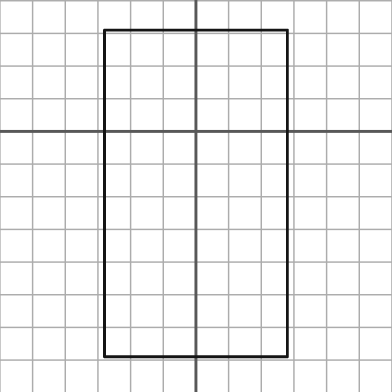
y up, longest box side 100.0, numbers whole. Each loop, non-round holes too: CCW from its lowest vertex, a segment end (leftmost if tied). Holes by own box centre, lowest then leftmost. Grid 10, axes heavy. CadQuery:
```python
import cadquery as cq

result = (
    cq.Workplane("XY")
    .moveTo(-28.0, -69.0)
    .lineTo(28.0, -69.0)
    .lineTo(28.0, 31.0)
    .lineTo(-28.0, 31.0)
    .close()
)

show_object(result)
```